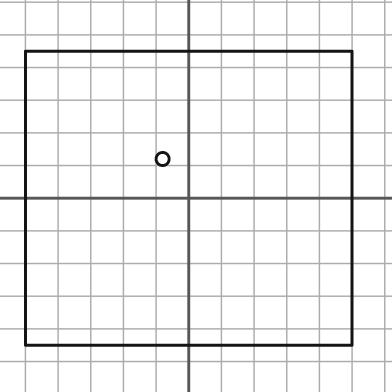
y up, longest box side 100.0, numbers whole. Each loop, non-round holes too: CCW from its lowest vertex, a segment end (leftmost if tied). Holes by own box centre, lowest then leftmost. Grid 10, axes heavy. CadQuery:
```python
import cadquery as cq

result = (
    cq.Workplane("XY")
    .moveTo(-50.0, -45.0)
    .lineTo(50.0, -45.0)
    .lineTo(50.0, 45.0)
    .lineTo(-50.0, 45.0)
    .close()
    .moveTo(-8.0, 12.0)
    .circle(2.0)
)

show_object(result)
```